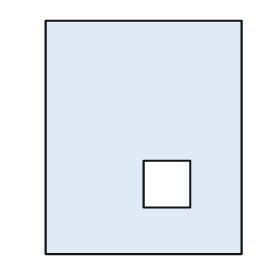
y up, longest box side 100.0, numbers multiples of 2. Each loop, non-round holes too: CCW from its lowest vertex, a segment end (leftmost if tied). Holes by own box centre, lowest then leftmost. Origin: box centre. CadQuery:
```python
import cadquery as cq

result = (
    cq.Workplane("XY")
    .moveTo(-42.0, -50.0)
    .lineTo(42.0, -50.0)
    .lineTo(42.0, 50.0)
    .lineTo(-42.0, 50.0)
    .close()
    .moveTo(0.0, -30.0)
    .lineTo(20.0, -30.0)
    .lineTo(20.0, -10.0)
    .lineTo(0.0, -10.0)
    .close()
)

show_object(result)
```